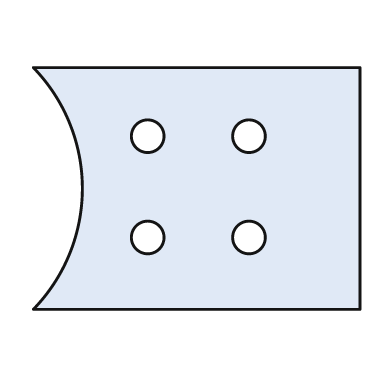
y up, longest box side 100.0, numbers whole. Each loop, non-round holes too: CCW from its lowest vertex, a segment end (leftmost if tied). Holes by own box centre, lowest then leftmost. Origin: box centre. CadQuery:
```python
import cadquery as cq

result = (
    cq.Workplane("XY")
    .moveTo(-50.0, -37.0)
    .lineTo(50.0, -37.0)
    .lineTo(50.0, 37.0)
    .lineTo(-50.0, 37.0)
    .threePointArc((-35.0, 0.0), (-50.0, -37.0))
    .close()
    .moveTo(-15.0, -15.0)
    .circle(5.0)
    .moveTo(16.0, -15.0)
    .circle(5.0)
    .moveTo(-15.0, 16.0)
    .circle(5.0)
    .moveTo(16.0, 16.0)
    .circle(5.0)
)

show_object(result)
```